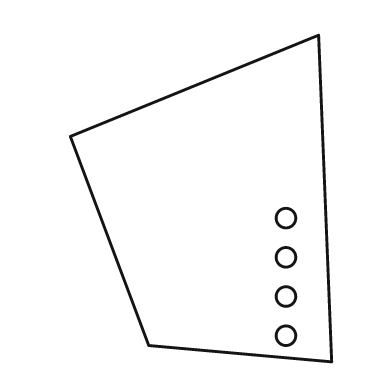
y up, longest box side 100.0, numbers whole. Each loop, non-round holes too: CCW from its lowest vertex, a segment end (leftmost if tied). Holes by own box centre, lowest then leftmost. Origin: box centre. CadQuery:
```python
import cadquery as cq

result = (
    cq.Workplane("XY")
    .moveTo(40.0, -50.0)
    .lineTo(36.0, 50.0)
    .lineTo(-40.0, 19.0)
    .lineTo(-16.0, -45.0)
    .close()
    .moveTo(26.0, -42.0)
    .circle(3.0)
    .moveTo(26.0, -30.0)
    .circle(3.0)
    .moveTo(26.0, -18.0)
    .circle(3.0)
    .moveTo(26.0, -6.0)
    .circle(3.0)
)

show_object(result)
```